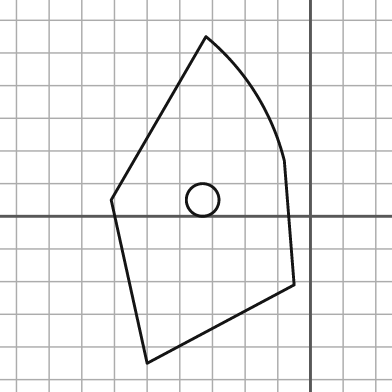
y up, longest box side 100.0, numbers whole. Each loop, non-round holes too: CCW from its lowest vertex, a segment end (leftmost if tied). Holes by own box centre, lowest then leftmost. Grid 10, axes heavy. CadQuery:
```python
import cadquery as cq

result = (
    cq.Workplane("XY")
    .moveTo(-50.0, -45.0)
    .lineTo(-5.0, -21.0)
    .lineTo(-8.0, 17.0)
    .threePointArc((-17.0, 38.0), (-32.0, 55.0))
    .lineTo(-61.0, 5.0)
    .close()
    .moveTo(-33.0, 5.0)
    .circle(5.0)
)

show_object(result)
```